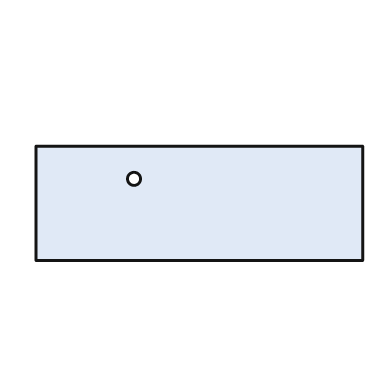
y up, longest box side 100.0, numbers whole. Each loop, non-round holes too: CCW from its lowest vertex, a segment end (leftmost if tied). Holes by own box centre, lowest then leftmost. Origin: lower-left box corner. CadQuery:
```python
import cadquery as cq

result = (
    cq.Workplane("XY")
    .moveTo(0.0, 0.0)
    .lineTo(100.0, 0.0)
    .lineTo(100.0, 35.0)
    .lineTo(0.0, 35.0)
    .close()
    .moveTo(30.0, 25.0)
    .circle(2.0)
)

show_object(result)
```